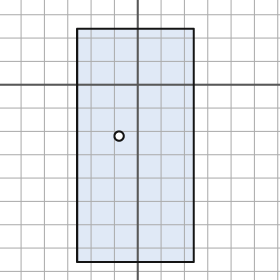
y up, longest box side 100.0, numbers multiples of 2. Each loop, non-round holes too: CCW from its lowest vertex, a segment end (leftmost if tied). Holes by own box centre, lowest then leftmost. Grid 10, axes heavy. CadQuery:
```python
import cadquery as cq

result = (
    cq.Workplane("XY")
    .moveTo(-26.0, -76.0)
    .lineTo(24.0, -76.0)
    .lineTo(24.0, 24.0)
    .lineTo(-26.0, 24.0)
    .close()
    .moveTo(-8.0, -22.0)
    .circle(2.0)
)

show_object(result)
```